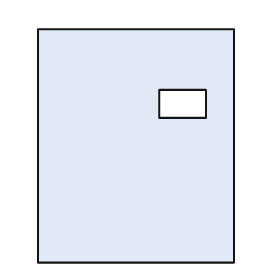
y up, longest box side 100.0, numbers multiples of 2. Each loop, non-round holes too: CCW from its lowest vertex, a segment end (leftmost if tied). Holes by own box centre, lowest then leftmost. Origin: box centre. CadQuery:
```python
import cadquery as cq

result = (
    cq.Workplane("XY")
    .moveTo(-42.0, -50.0)
    .lineTo(42.0, -50.0)
    .lineTo(42.0, 50.0)
    .lineTo(-42.0, 50.0)
    .close()
    .moveTo(10.0, 12.0)
    .lineTo(30.0, 12.0)
    .lineTo(30.0, 24.0)
    .lineTo(10.0, 24.0)
    .close()
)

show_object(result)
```